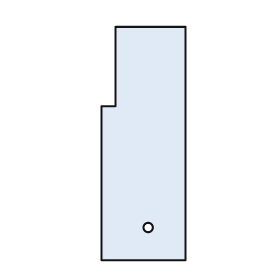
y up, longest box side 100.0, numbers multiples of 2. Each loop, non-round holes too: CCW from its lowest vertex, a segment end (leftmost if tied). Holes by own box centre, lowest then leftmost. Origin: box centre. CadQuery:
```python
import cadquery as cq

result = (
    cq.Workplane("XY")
    .moveTo(-18.0, -50.0)
    .lineTo(18.0, -50.0)
    .lineTo(18.0, 50.0)
    .lineTo(-12.0, 50.0)
    .lineTo(-12.0, 16.0)
    .lineTo(-18.0, 16.0)
    .close()
    .moveTo(2.0, -36.0)
    .circle(2.0)
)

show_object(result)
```